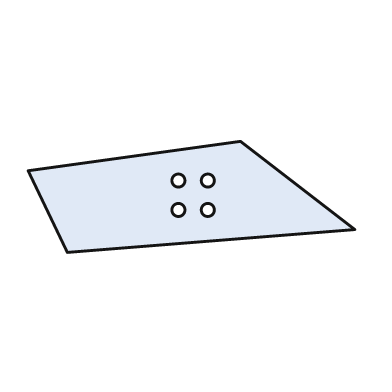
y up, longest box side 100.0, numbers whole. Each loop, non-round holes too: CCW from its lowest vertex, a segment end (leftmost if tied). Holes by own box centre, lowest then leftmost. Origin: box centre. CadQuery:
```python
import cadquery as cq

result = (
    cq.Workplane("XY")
    .moveTo(-38.0, -17.0)
    .lineTo(50.0, -10.0)
    .lineTo(15.0, 17.0)
    .lineTo(-50.0, 8.0)
    .close()
    .moveTo(-4.0, -4.0)
    .circle(2.0)
    .moveTo(5.0, -4.0)
    .circle(2.0)
    .moveTo(-4.0, 5.0)
    .circle(2.0)
    .moveTo(5.0, 5.0)
    .circle(2.0)
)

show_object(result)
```